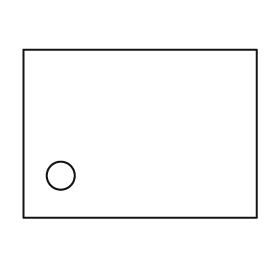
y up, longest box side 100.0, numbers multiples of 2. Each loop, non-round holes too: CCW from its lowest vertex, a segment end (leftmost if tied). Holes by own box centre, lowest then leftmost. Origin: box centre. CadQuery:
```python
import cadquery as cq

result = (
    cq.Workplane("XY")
    .moveTo(-50.0, -36.0)
    .lineTo(50.0, -36.0)
    .lineTo(50.0, 36.0)
    .lineTo(-50.0, 36.0)
    .close()
    .moveTo(-34.0, -18.0)
    .circle(6.0)
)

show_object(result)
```